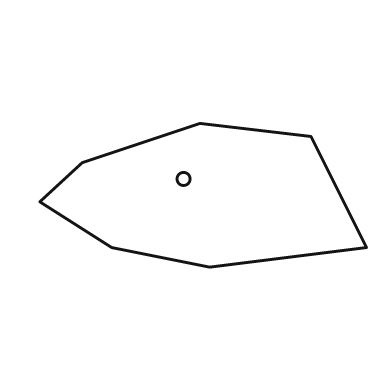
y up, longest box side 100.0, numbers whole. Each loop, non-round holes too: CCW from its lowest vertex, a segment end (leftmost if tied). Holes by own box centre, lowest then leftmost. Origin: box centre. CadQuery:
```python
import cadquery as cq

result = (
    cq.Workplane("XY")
    .moveTo(2.0, -22.0)
    .lineTo(50.0, -16.0)
    .lineTo(33.0, 18.0)
    .lineTo(-1.0, 22.0)
    .lineTo(-37.0, 10.0)
    .lineTo(-50.0, -2.0)
    .lineTo(-28.0, -16.0)
    .close()
    .moveTo(-6.0, 5.0)
    .circle(2.0)
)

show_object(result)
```